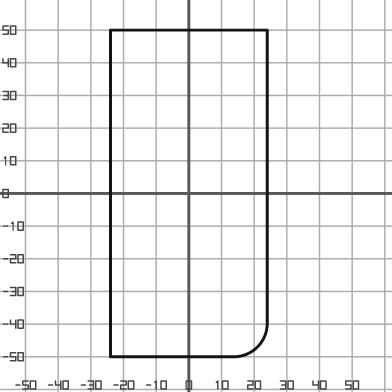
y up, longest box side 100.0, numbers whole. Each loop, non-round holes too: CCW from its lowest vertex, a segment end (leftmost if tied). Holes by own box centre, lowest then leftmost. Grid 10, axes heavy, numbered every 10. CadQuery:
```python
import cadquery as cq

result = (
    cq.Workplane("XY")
    .moveTo(-24.0, -50.0)
    .lineTo(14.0, -50.0)
    .threePointArc((21.0, -47.0), (24.0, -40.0))
    .lineTo(24.0, 50.0)
    .lineTo(-24.0, 50.0)
    .close()
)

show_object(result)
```